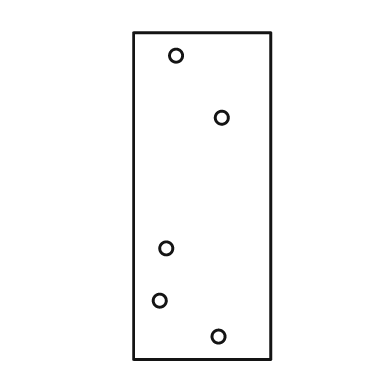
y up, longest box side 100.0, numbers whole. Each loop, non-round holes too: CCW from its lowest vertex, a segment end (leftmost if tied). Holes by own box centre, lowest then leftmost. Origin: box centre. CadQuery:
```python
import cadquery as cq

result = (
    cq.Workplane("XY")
    .moveTo(-21.0, -50.0)
    .lineTo(21.0, -50.0)
    .lineTo(21.0, 50.0)
    .lineTo(-21.0, 50.0)
    .close()
    .moveTo(5.0, -43.0)
    .circle(2.0)
    .moveTo(-13.0, -32.0)
    .circle(2.0)
    .moveTo(-11.0, -16.0)
    .circle(2.0)
    .moveTo(6.0, 24.0)
    .circle(2.0)
    .moveTo(-8.0, 43.0)
    .circle(2.0)
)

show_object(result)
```